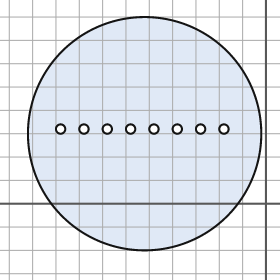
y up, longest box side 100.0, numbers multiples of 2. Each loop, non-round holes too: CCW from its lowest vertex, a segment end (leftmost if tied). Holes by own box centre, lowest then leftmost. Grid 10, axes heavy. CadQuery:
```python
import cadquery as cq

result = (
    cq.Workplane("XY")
    .moveTo(-52.0, 30.0)
    .circle(50.0)
    .moveTo(-88.0, 32.0)
    .circle(2.0)
    .moveTo(-78.0, 32.0)
    .circle(2.0)
    .moveTo(-68.0, 32.0)
    .circle(2.0)
    .moveTo(-58.0, 32.0)
    .circle(2.0)
    .moveTo(-48.0, 32.0)
    .circle(2.0)
    .moveTo(-38.0, 32.0)
    .circle(2.0)
    .moveTo(-28.0, 32.0)
    .circle(2.0)
    .moveTo(-18.0, 32.0)
    .circle(2.0)
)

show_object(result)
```